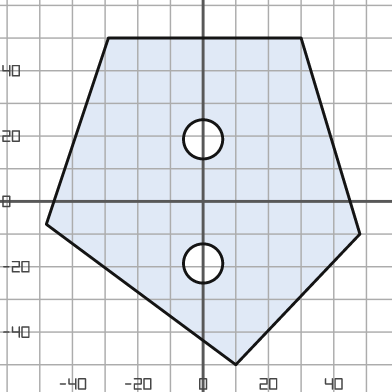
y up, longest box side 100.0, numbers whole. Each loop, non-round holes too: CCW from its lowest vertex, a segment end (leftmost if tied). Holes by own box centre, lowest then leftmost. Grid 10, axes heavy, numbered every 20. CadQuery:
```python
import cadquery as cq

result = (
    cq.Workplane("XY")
    .moveTo(10.0, -50.0)
    .lineTo(48.0, -10.0)
    .lineTo(30.0, 50.0)
    .lineTo(-29.0, 50.0)
    .lineTo(-48.0, -7.0)
    .close()
    .moveTo(0.0, -19.0)
    .circle(6.0)
    .moveTo(0.0, 19.0)
    .circle(6.0)
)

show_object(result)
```